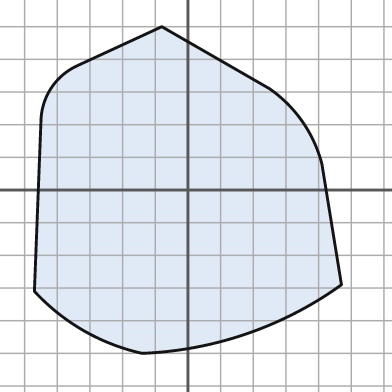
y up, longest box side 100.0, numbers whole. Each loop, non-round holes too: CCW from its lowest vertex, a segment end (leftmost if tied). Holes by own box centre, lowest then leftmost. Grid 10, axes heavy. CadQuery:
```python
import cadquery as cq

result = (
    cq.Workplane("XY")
    .moveTo(-14.0, -50.0)
    .threePointArc((18.0, -44.0), (47.0, -29.0))
    .lineTo(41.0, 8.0)
    .threePointArc((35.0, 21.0), (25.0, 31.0))
    .lineTo(-8.0, 50.0)
    .lineTo(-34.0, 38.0)
    .threePointArc((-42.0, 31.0), (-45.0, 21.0))
    .lineTo(-47.0, -31.0)
    .threePointArc((-32.0, -43.0), (-14.0, -50.0))
    .close()
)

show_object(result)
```